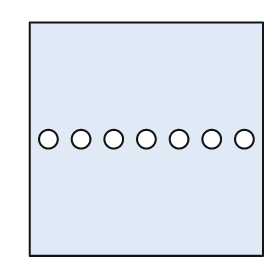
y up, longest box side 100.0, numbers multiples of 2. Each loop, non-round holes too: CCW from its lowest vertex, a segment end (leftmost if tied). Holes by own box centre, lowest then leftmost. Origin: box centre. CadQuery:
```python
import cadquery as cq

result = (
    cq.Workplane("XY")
    .moveTo(-50.0, -50.0)
    .lineTo(50.0, -50.0)
    .lineTo(50.0, 50.0)
    .lineTo(-50.0, 50.0)
    .close()
    .moveTo(-42.0, 0.0)
    .circle(4.0)
    .moveTo(-28.0, 0.0)
    .circle(4.0)
    .moveTo(-14.0, 0.0)
    .circle(4.0)
    .moveTo(0.0, 0.0)
    .circle(4.0)
    .moveTo(14.0, 0.0)
    .circle(4.0)
    .moveTo(28.0, 0.0)
    .circle(4.0)
    .moveTo(42.0, 0.0)
    .circle(4.0)
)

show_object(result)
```